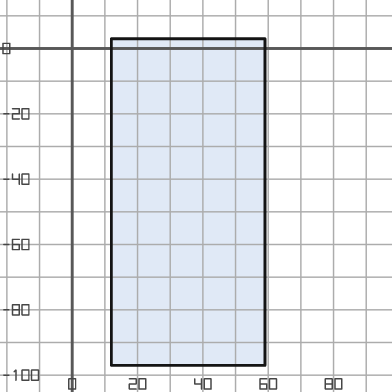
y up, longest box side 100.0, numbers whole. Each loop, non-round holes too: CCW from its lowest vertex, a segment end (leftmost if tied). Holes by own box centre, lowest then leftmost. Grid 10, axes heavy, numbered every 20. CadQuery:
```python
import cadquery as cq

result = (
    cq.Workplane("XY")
    .moveTo(12.0, -97.0)
    .lineTo(59.0, -97.0)
    .lineTo(59.0, 3.0)
    .lineTo(12.0, 3.0)
    .close()
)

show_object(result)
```